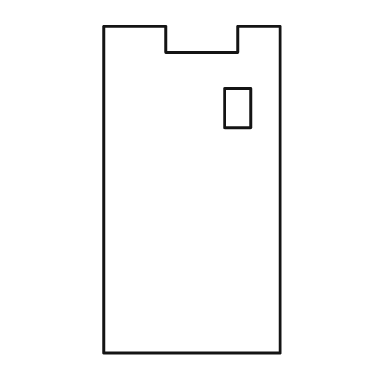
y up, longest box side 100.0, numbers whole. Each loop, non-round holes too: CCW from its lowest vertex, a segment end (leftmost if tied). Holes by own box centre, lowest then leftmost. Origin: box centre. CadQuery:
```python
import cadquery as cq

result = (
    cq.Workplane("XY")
    .moveTo(-27.0, -50.0)
    .lineTo(27.0, -50.0)
    .lineTo(27.0, 50.0)
    .lineTo(14.0, 50.0)
    .lineTo(14.0, 42.0)
    .lineTo(-8.0, 42.0)
    .lineTo(-8.0, 50.0)
    .lineTo(-27.0, 50.0)
    .close()
    .moveTo(10.0, 19.0)
    .lineTo(18.0, 19.0)
    .lineTo(18.0, 31.0)
    .lineTo(10.0, 31.0)
    .close()
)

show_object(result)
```